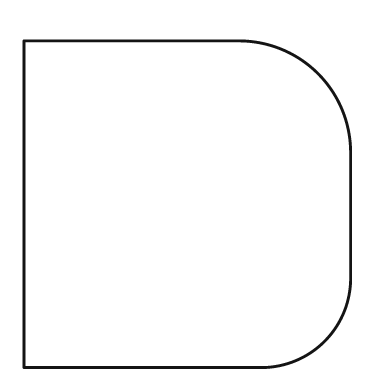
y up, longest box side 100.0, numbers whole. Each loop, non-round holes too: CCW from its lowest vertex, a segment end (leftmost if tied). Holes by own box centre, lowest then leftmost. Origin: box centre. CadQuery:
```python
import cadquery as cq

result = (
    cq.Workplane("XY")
    .moveTo(-50.0, -50.0)
    .lineTo(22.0, -50.0)
    .threePointArc((42.0, -42.0), (50.0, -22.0))
    .lineTo(50.0, 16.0)
    .threePointArc((40.0, 40.0), (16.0, 50.0))
    .lineTo(-50.0, 50.0)
    .close()
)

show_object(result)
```